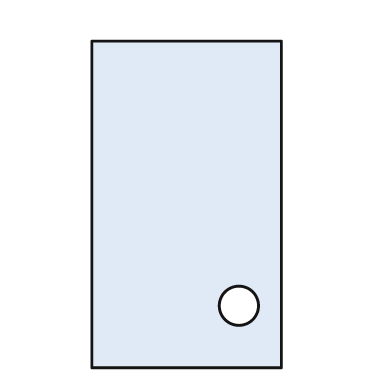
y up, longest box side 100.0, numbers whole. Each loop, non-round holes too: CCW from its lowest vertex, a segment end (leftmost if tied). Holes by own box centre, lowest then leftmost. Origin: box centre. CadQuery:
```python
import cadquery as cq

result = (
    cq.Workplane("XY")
    .moveTo(-29.0, -50.0)
    .lineTo(29.0, -50.0)
    .lineTo(29.0, 50.0)
    .lineTo(-29.0, 50.0)
    .close()
    .moveTo(16.0, -31.0)
    .circle(6.0)
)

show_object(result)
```